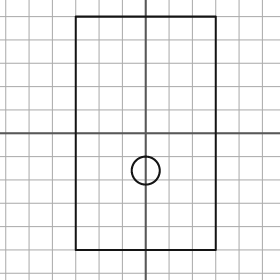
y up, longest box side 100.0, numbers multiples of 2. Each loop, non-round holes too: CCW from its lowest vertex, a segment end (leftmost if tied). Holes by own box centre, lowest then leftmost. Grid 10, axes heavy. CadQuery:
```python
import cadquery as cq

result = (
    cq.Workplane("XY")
    .moveTo(-30.0, -50.0)
    .lineTo(30.0, -50.0)
    .lineTo(30.0, 50.0)
    .lineTo(-30.0, 50.0)
    .close()
    .moveTo(0.0, -16.0)
    .circle(6.0)
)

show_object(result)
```